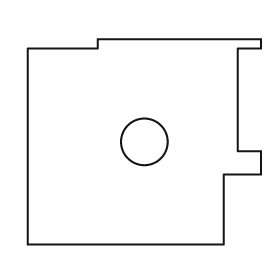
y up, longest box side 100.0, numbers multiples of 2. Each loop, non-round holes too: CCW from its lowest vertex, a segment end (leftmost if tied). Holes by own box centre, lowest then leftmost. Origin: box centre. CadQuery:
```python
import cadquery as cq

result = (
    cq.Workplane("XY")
    .moveTo(-50.0, -44.0)
    .lineTo(34.0, -44.0)
    .lineTo(34.0, -14.0)
    .lineTo(50.0, -14.0)
    .lineTo(50.0, -4.0)
    .lineTo(40.0, -4.0)
    .lineTo(40.0, 40.0)
    .lineTo(50.0, 40.0)
    .lineTo(50.0, 44.0)
    .lineTo(-20.0, 44.0)
    .lineTo(-20.0, 40.0)
    .lineTo(-50.0, 40.0)
    .close()
    .moveTo(0.0, 0.0)
    .circle(10.0)
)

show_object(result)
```